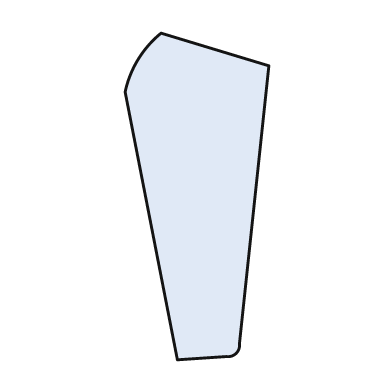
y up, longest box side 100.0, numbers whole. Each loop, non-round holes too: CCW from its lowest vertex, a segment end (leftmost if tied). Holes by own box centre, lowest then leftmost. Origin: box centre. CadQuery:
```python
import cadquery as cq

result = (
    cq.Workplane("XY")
    .moveTo(-6.0, -50.0)
    .lineTo(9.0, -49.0)
    .threePointArc((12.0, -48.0), (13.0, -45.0))
    .lineTo(22.0, 40.0)
    .lineTo(-11.0, 50.0)
    .threePointArc((-18.0, 42.0), (-22.0, 32.0))
    .close()
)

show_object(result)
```